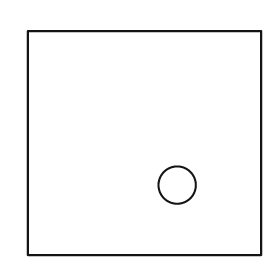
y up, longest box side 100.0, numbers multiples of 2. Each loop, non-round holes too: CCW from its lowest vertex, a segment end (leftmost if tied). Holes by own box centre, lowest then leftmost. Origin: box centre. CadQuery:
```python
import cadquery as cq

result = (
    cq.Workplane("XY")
    .moveTo(-50.0, -48.0)
    .lineTo(50.0, -48.0)
    .lineTo(50.0, 48.0)
    .lineTo(-50.0, 48.0)
    .close()
    .moveTo(14.0, -18.0)
    .circle(8.0)
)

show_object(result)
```